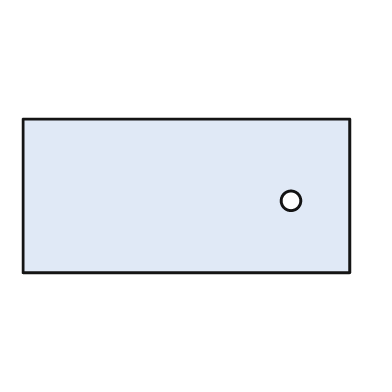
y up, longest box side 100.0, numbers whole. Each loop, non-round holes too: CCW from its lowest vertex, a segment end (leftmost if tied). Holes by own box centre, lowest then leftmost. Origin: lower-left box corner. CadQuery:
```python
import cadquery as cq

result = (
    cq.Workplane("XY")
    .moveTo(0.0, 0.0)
    .lineTo(100.0, 0.0)
    .lineTo(100.0, 47.0)
    .lineTo(0.0, 47.0)
    .close()
    .moveTo(82.0, 22.0)
    .circle(3.0)
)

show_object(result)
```